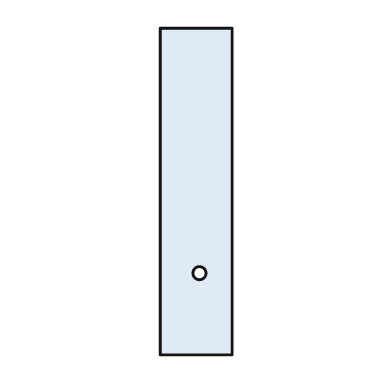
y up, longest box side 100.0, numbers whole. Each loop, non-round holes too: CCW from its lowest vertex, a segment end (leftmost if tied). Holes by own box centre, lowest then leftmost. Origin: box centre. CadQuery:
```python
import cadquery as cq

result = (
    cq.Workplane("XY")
    .moveTo(-11.0, -50.0)
    .lineTo(11.0, -50.0)
    .lineTo(11.0, 50.0)
    .lineTo(-11.0, 50.0)
    .close()
    .moveTo(1.0, -25.0)
    .circle(2.0)
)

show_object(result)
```